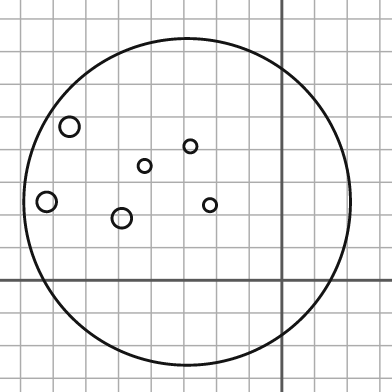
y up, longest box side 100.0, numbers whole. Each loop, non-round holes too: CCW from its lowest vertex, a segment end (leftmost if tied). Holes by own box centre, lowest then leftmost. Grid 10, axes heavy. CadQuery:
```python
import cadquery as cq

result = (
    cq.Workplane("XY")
    .moveTo(-29.0, 24.0)
    .circle(50.0)
    .moveTo(-49.0, 19.0)
    .circle(3.0)
    .moveTo(-22.0, 23.0)
    .circle(2.0)
    .moveTo(-72.0, 24.0)
    .circle(3.0)
    .moveTo(-42.0, 35.0)
    .circle(2.0)
    .moveTo(-28.0, 41.0)
    .circle(2.0)
    .moveTo(-65.0, 47.0)
    .circle(3.0)
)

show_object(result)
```